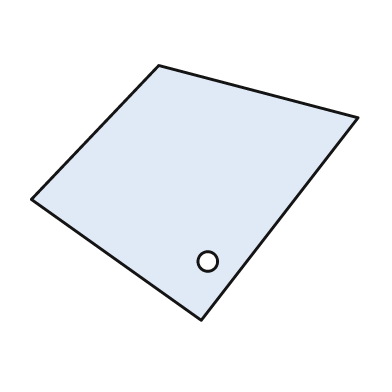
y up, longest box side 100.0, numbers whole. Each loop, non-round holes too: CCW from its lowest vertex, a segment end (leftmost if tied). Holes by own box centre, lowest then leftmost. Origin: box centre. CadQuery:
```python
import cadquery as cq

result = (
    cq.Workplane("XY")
    .moveTo(2.0, -39.0)
    .lineTo(50.0, 23.0)
    .lineTo(-11.0, 39.0)
    .lineTo(-50.0, -2.0)
    .close()
    .moveTo(4.0, -21.0)
    .circle(3.0)
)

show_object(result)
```